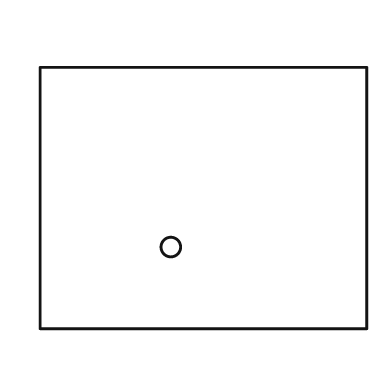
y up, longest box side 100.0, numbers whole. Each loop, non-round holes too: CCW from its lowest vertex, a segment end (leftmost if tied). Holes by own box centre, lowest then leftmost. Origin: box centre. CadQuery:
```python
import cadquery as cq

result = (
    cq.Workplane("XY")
    .moveTo(-50.0, -40.0)
    .lineTo(50.0, -40.0)
    .lineTo(50.0, 40.0)
    .lineTo(-50.0, 40.0)
    .close()
    .moveTo(-10.0, -15.0)
    .circle(3.0)
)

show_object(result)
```